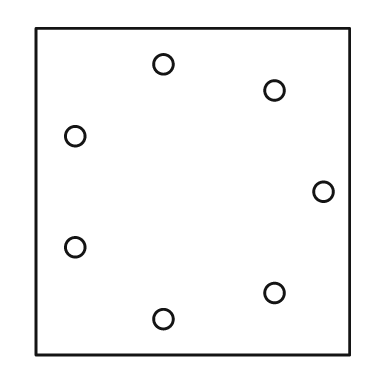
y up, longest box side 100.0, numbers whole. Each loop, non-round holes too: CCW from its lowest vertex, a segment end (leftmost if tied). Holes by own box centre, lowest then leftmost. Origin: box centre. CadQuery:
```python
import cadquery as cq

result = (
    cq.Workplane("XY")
    .moveTo(-48.0, -50.0)
    .lineTo(48.0, -50.0)
    .lineTo(48.0, 50.0)
    .lineTo(-48.0, 50.0)
    .close()
    .moveTo(-9.0, -39.0)
    .circle(3.0)
    .moveTo(25.0, -31.0)
    .circle(3.0)
    .moveTo(-36.0, -17.0)
    .circle(3.0)
    .moveTo(40.0, 0.0)
    .circle(3.0)
    .moveTo(-36.0, 17.0)
    .circle(3.0)
    .moveTo(25.0, 31.0)
    .circle(3.0)
    .moveTo(-9.0, 39.0)
    .circle(3.0)
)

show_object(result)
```